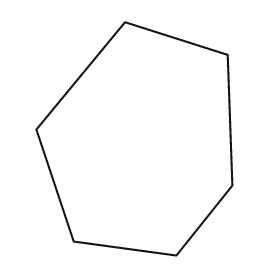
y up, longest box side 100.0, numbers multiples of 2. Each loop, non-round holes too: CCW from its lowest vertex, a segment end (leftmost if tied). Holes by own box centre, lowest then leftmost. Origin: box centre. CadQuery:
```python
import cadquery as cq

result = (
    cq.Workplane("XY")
    .moveTo(18.0, -50.0)
    .lineTo(42.0, -20.0)
    .lineTo(40.0, 36.0)
    .lineTo(-4.0, 50.0)
    .lineTo(-42.0, 4.0)
    .lineTo(-26.0, -44.0)
    .close()
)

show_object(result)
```